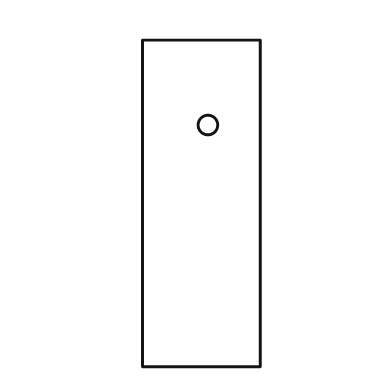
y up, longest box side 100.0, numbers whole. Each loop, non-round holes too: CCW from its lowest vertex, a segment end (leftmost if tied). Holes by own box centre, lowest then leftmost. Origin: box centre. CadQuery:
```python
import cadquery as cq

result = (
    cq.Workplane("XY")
    .moveTo(-18.0, -50.0)
    .lineTo(18.0, -50.0)
    .lineTo(18.0, 50.0)
    .lineTo(-18.0, 50.0)
    .close()
    .moveTo(2.0, 24.0)
    .circle(3.0)
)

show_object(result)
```